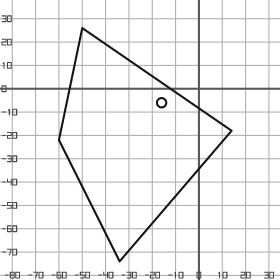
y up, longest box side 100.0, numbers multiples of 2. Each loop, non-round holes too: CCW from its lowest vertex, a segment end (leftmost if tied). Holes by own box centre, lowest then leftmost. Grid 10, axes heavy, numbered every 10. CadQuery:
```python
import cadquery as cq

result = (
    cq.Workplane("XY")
    .moveTo(-34.0, -74.0)
    .lineTo(14.0, -18.0)
    .lineTo(-50.0, 26.0)
    .lineTo(-60.0, -22.0)
    .close()
    .moveTo(-16.0, -6.0)
    .circle(2.0)
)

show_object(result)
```